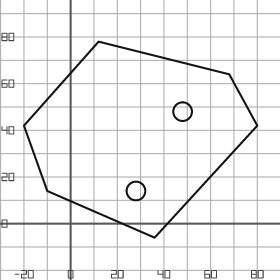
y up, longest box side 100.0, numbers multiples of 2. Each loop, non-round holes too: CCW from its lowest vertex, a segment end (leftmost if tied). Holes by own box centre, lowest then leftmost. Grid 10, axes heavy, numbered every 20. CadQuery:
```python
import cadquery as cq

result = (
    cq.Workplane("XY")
    .moveTo(36.0, -6.0)
    .lineTo(80.0, 42.0)
    .lineTo(68.0, 64.0)
    .lineTo(12.0, 78.0)
    .lineTo(-20.0, 42.0)
    .lineTo(-10.0, 14.0)
    .close()
    .moveTo(28.0, 14.0)
    .circle(4.0)
    .moveTo(48.0, 48.0)
    .circle(4.0)
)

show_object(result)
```